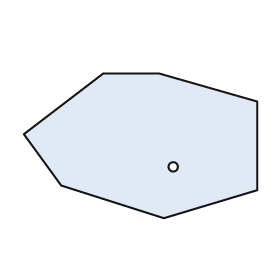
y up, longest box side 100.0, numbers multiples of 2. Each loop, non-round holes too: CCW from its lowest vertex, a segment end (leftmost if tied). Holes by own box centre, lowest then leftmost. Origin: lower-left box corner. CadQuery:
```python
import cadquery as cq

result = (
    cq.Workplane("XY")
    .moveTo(60.0, 0.0)
    .lineTo(100.0, 12.0)
    .lineTo(100.0, 50.0)
    .lineTo(58.0, 62.0)
    .lineTo(34.0, 62.0)
    .lineTo(0.0, 36.0)
    .lineTo(16.0, 14.0)
    .close()
    .moveTo(64.0, 22.0)
    .circle(2.0)
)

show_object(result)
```